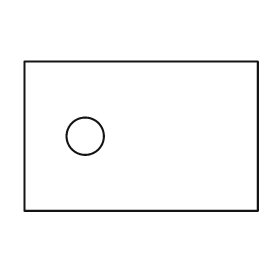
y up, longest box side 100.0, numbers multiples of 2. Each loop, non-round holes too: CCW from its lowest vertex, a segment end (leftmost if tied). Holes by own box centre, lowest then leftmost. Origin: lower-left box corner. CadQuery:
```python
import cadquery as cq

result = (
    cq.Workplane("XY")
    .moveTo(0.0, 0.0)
    .lineTo(100.0, 0.0)
    .lineTo(100.0, 64.0)
    .lineTo(0.0, 64.0)
    .close()
    .moveTo(26.0, 32.0)
    .circle(8.0)
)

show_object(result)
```